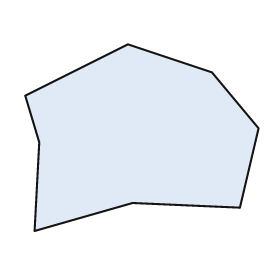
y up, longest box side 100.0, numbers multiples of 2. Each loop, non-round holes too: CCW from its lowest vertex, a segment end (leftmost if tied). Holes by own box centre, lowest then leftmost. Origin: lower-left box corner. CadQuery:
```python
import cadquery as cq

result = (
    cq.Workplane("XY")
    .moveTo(4.0, 0.0)
    .lineTo(46.0, 12.0)
    .lineTo(92.0, 10.0)
    .lineTo(100.0, 44.0)
    .lineTo(80.0, 68.0)
    .lineTo(44.0, 80.0)
    .lineTo(0.0, 58.0)
    .lineTo(6.0, 38.0)
    .close()
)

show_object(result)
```